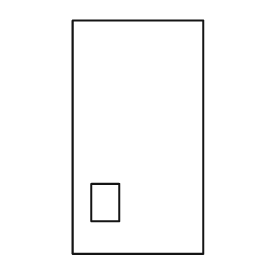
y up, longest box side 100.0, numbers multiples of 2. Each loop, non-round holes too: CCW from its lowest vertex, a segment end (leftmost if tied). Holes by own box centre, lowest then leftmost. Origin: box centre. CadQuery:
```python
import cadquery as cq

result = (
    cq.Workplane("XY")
    .moveTo(-28.0, -50.0)
    .lineTo(28.0, -50.0)
    .lineTo(28.0, 50.0)
    .lineTo(-28.0, 50.0)
    .close()
    .moveTo(-20.0, -36.0)
    .lineTo(-8.0, -36.0)
    .lineTo(-8.0, -20.0)
    .lineTo(-20.0, -20.0)
    .close()
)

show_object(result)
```